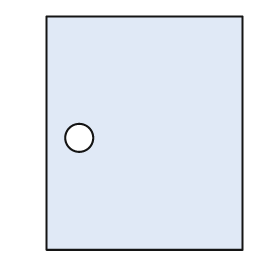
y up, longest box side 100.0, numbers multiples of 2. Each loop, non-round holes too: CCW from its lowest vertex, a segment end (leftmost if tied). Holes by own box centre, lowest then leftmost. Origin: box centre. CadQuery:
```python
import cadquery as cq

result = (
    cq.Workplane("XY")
    .moveTo(-42.0, -50.0)
    .lineTo(42.0, -50.0)
    .lineTo(42.0, 50.0)
    .lineTo(-42.0, 50.0)
    .close()
    .moveTo(-28.0, -2.0)
    .circle(6.0)
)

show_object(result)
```